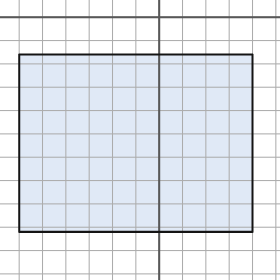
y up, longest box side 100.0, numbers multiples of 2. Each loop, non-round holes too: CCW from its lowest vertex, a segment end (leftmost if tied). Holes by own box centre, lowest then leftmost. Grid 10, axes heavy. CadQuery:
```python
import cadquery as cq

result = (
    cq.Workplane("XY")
    .moveTo(-60.0, -92.0)
    .lineTo(40.0, -92.0)
    .lineTo(40.0, -16.0)
    .lineTo(-60.0, -16.0)
    .close()
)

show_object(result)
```